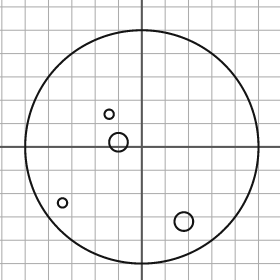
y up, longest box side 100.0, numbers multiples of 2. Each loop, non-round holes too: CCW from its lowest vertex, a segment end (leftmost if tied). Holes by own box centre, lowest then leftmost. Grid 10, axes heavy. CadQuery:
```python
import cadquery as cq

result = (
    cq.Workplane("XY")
    .moveTo(0.0, 0.0)
    .circle(50.0)
    .moveTo(18.0, -32.0)
    .circle(4.0)
    .moveTo(-34.0, -24.0)
    .circle(2.0)
    .moveTo(-10.0, 2.0)
    .circle(4.0)
    .moveTo(-14.0, 14.0)
    .circle(2.0)
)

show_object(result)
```